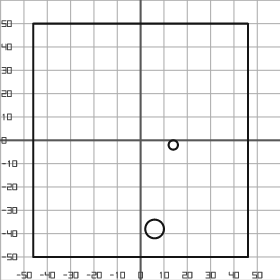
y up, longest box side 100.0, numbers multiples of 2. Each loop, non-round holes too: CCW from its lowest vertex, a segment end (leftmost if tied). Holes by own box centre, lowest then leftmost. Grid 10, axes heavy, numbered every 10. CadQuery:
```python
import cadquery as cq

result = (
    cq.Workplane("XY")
    .moveTo(-46.0, -50.0)
    .lineTo(46.0, -50.0)
    .lineTo(46.0, 50.0)
    .lineTo(-46.0, 50.0)
    .close()
    .moveTo(6.0, -38.0)
    .circle(4.0)
    .moveTo(14.0, -2.0)
    .circle(2.0)
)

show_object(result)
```